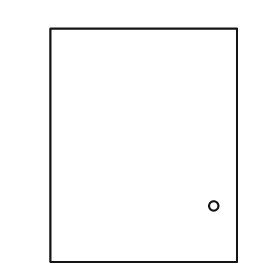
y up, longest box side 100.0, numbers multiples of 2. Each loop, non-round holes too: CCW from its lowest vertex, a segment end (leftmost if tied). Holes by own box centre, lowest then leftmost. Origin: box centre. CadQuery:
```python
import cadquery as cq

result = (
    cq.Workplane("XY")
    .moveTo(-40.0, -50.0)
    .lineTo(40.0, -50.0)
    .lineTo(40.0, 50.0)
    .lineTo(-40.0, 50.0)
    .close()
    .moveTo(30.0, -26.0)
    .circle(2.0)
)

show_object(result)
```